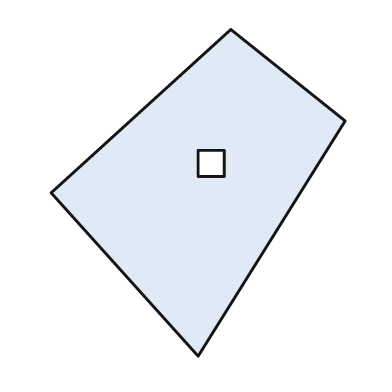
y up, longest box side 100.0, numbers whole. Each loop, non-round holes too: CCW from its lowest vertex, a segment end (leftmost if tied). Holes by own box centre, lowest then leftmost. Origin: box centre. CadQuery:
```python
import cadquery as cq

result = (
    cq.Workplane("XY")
    .moveTo(0.0, -50.0)
    .lineTo(45.0, 22.0)
    .lineTo(10.0, 50.0)
    .lineTo(-45.0, 0.0)
    .close()
    .moveTo(0.0, 5.0)
    .lineTo(8.0, 5.0)
    .lineTo(8.0, 13.0)
    .lineTo(0.0, 13.0)
    .close()
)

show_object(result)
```